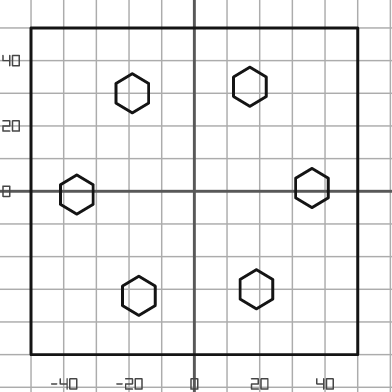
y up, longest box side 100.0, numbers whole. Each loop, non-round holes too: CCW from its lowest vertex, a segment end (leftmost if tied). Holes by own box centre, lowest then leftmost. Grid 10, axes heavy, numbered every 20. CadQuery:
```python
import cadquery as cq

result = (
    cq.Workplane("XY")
    .moveTo(-50.0, -50.0)
    .lineTo(50.0, -50.0)
    .lineTo(50.0, 50.0)
    .lineTo(-50.0, 50.0)
    .close()
    .moveTo(-17.0, -38.0)
    .lineTo(-12.0, -35.0)
    .lineTo(-12.0, -29.0)
    .lineTo(-17.0, -26.0)
    .lineTo(-22.0, -29.0)
    .lineTo(-22.0, -35.0)
    .close()
    .moveTo(19.0, -36.0)
    .lineTo(24.0, -33.0)
    .lineTo(24.0, -27.0)
    .lineTo(19.0, -24.0)
    .lineTo(14.0, -27.0)
    .lineTo(14.0, -33.0)
    .close()
    .moveTo(-36.0, -7.0)
    .lineTo(-31.0, -4.0)
    .lineTo(-31.0, 2.0)
    .lineTo(-36.0, 5.0)
    .lineTo(-41.0, 2.0)
    .lineTo(-41.0, -4.0)
    .close()
    .moveTo(36.0, -5.0)
    .lineTo(41.0, -2.0)
    .lineTo(41.0, 4.0)
    .lineTo(36.0, 7.0)
    .lineTo(31.0, 4.0)
    .lineTo(31.0, -2.0)
    .close()
    .moveTo(-19.0, 24.0)
    .lineTo(-14.0, 27.0)
    .lineTo(-14.0, 33.0)
    .lineTo(-19.0, 36.0)
    .lineTo(-24.0, 33.0)
    .lineTo(-24.0, 27.0)
    .close()
    .moveTo(17.0, 26.0)
    .lineTo(22.0, 29.0)
    .lineTo(22.0, 35.0)
    .lineTo(17.0, 38.0)
    .lineTo(12.0, 35.0)
    .lineTo(12.0, 29.0)
    .close()
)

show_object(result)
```